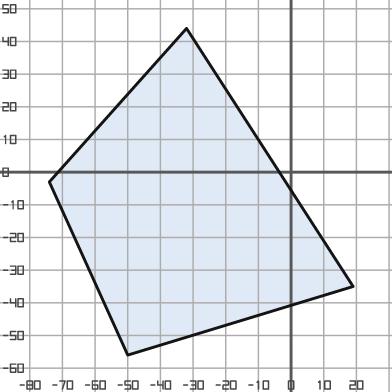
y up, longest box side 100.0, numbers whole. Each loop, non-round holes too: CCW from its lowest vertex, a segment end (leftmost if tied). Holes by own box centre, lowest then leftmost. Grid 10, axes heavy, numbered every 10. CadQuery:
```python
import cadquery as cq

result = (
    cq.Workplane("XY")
    .moveTo(-50.0, -56.0)
    .lineTo(19.0, -35.0)
    .lineTo(-32.0, 44.0)
    .lineTo(-74.0, -3.0)
    .close()
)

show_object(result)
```